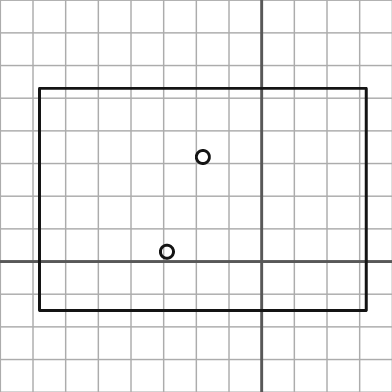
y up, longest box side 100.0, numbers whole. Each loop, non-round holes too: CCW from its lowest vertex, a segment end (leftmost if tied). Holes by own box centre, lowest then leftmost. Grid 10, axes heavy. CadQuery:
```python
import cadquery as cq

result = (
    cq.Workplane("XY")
    .moveTo(-68.0, -15.0)
    .lineTo(32.0, -15.0)
    .lineTo(32.0, 53.0)
    .lineTo(-68.0, 53.0)
    .close()
    .moveTo(-29.0, 3.0)
    .circle(2.0)
    .moveTo(-18.0, 32.0)
    .circle(2.0)
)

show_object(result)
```